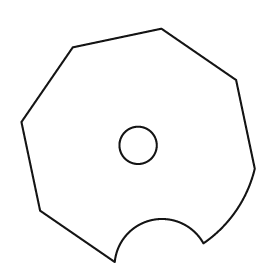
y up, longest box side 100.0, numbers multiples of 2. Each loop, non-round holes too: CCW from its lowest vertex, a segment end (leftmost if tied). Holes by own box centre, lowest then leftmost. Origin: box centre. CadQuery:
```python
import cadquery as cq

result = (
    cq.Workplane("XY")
    .moveTo(-10.0, -50.0)
    .threePointArc((6.0, -32.0), (28.0, -42.0))
    .threePointArc((42.0, -28.0), (50.0, -10.0))
    .lineTo(42.0, 28.0)
    .lineTo(10.0, 50.0)
    .lineTo(-28.0, 42.0)
    .lineTo(-50.0, 10.0)
    .lineTo(-42.0, -28.0)
    .close()
    .moveTo(0.0, 0.0)
    .circle(8.0)
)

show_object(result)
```